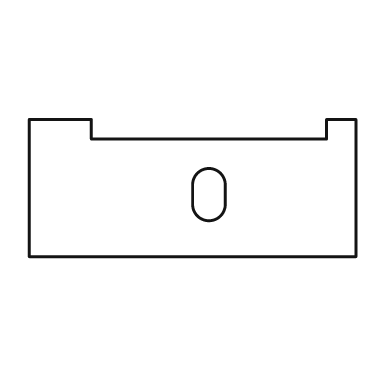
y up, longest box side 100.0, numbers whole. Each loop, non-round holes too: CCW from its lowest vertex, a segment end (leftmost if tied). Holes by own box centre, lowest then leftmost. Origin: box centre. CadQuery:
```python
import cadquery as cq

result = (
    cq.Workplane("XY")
    .moveTo(-50.0, -21.0)
    .lineTo(50.0, -21.0)
    .lineTo(50.0, 21.0)
    .lineTo(41.0, 21.0)
    .lineTo(41.0, 15.0)
    .lineTo(-31.0, 15.0)
    .lineTo(-31.0, 21.0)
    .lineTo(-50.0, 21.0)
    .close()
    .moveTo(0.0, -5.0)
    .threePointArc((5.0, -10.0), (10.0, -5.0))
    .lineTo(10.0, 1.0)
    .threePointArc((5.0, 6.0), (0.0, 1.0))
    .close()
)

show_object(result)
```